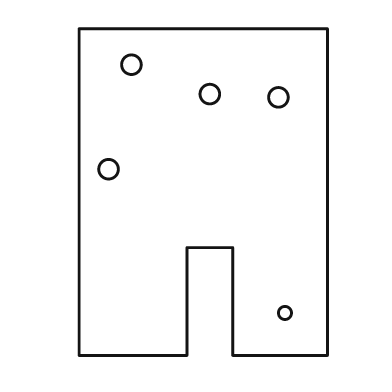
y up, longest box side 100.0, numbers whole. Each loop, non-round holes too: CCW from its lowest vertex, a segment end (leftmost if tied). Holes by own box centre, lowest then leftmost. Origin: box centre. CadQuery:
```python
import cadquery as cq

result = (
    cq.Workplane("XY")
    .moveTo(-38.0, -50.0)
    .lineTo(-5.0, -50.0)
    .lineTo(-5.0, -17.0)
    .lineTo(9.0, -17.0)
    .lineTo(9.0, -50.0)
    .lineTo(38.0, -50.0)
    .lineTo(38.0, 50.0)
    .lineTo(-38.0, 50.0)
    .close()
    .moveTo(25.0, -37.0)
    .circle(2.0)
    .moveTo(-29.0, 7.0)
    .circle(3.0)
    .moveTo(23.0, 29.0)
    .circle(3.0)
    .moveTo(2.0, 30.0)
    .circle(3.0)
    .moveTo(-22.0, 39.0)
    .circle(3.0)
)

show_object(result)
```